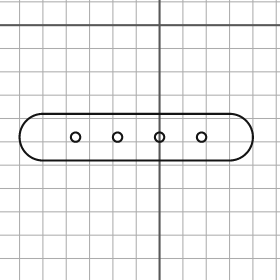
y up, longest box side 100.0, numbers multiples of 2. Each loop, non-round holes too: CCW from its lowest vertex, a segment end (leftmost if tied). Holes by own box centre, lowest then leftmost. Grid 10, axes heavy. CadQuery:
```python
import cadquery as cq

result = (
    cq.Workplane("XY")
    .moveTo(-50.0, -58.0)
    .lineTo(30.0, -58.0)
    .threePointArc((40.0, -48.0), (30.0, -38.0))
    .lineTo(-50.0, -38.0)
    .threePointArc((-60.0, -48.0), (-50.0, -58.0))
    .close()
    .moveTo(-36.0, -48.0)
    .circle(2.0)
    .moveTo(-18.0, -48.0)
    .circle(2.0)
    .moveTo(0.0, -48.0)
    .circle(2.0)
    .moveTo(18.0, -48.0)
    .circle(2.0)
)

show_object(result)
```